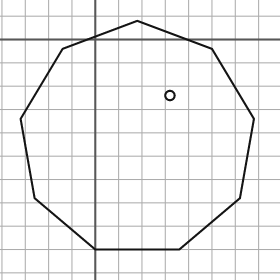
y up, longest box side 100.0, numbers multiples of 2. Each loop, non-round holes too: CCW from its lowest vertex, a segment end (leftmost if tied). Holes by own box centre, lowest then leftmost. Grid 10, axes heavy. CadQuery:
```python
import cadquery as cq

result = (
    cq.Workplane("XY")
    .moveTo(0.0, -90.0)
    .lineTo(36.0, -90.0)
    .lineTo(62.0, -68.0)
    .lineTo(68.0, -34.0)
    .lineTo(50.0, -4.0)
    .lineTo(18.0, 8.0)
    .lineTo(-14.0, -4.0)
    .lineTo(-32.0, -34.0)
    .lineTo(-26.0, -68.0)
    .close()
    .moveTo(32.0, -24.0)
    .circle(2.0)
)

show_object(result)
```